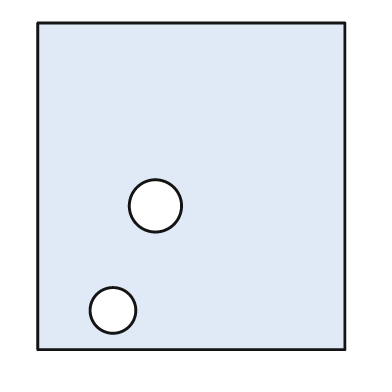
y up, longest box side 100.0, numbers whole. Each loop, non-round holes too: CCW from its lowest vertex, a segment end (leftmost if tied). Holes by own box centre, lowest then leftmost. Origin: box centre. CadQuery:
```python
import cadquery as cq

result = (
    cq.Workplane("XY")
    .moveTo(-47.0, -50.0)
    .lineTo(47.0, -50.0)
    .lineTo(47.0, 50.0)
    .lineTo(-47.0, 50.0)
    .close()
    .moveTo(-24.0, -38.0)
    .circle(7.0)
    .moveTo(-11.0, -6.0)
    .circle(8.0)
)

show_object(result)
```